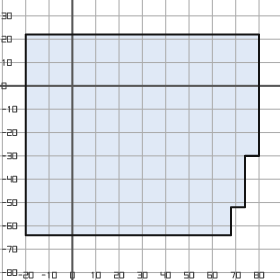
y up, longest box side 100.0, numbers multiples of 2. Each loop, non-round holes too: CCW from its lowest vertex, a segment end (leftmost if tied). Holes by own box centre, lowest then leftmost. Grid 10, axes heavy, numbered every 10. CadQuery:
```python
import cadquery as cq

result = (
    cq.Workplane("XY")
    .moveTo(-20.0, -64.0)
    .lineTo(68.0, -64.0)
    .lineTo(68.0, -52.0)
    .lineTo(74.0, -52.0)
    .lineTo(74.0, -30.0)
    .lineTo(80.0, -30.0)
    .lineTo(80.0, 22.0)
    .lineTo(-20.0, 22.0)
    .close()
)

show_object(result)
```